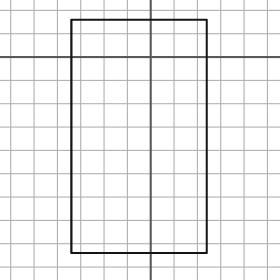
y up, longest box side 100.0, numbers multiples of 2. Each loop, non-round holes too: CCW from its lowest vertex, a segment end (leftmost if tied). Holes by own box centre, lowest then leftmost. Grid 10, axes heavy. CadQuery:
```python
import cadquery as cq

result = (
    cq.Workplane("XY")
    .moveTo(-34.0, -84.0)
    .lineTo(24.0, -84.0)
    .lineTo(24.0, 16.0)
    .lineTo(-34.0, 16.0)
    .close()
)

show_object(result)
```